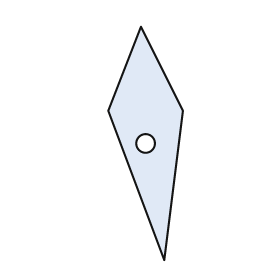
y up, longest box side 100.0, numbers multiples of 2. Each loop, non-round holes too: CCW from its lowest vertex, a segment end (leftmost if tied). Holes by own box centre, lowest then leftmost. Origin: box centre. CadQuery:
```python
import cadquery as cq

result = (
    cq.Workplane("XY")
    .moveTo(8.0, -50.0)
    .lineTo(16.0, 14.0)
    .lineTo(-2.0, 50.0)
    .lineTo(-16.0, 14.0)
    .close()
    .moveTo(0.0, 0.0)
    .circle(4.0)
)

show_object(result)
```